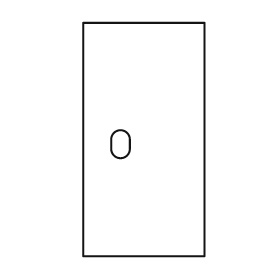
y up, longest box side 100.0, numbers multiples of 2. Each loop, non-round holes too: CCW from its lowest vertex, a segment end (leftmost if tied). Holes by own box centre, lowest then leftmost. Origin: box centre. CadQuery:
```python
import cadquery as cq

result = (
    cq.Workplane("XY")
    .moveTo(-26.0, -50.0)
    .lineTo(26.0, -50.0)
    .lineTo(26.0, 50.0)
    .lineTo(-26.0, 50.0)
    .close()
    .moveTo(-14.0, -4.0)
    .threePointArc((-10.0, -8.0), (-6.0, -4.0))
    .lineTo(-6.0, 0.0)
    .threePointArc((-10.0, 4.0), (-14.0, 0.0))
    .close()
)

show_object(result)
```